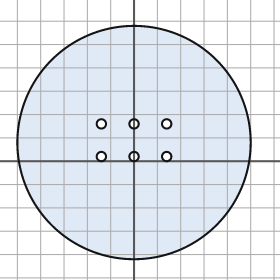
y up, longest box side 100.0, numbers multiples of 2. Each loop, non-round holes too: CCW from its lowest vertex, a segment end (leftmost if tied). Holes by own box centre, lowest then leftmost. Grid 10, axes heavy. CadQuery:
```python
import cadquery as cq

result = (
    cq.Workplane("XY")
    .moveTo(0.0, 8.0)
    .circle(50.0)
    .moveTo(-14.0, 2.0)
    .circle(2.0)
    .moveTo(0.0, 2.0)
    .circle(2.0)
    .moveTo(14.0, 2.0)
    .circle(2.0)
    .moveTo(-14.0, 16.0)
    .circle(2.0)
    .moveTo(0.0, 16.0)
    .circle(2.0)
    .moveTo(14.0, 16.0)
    .circle(2.0)
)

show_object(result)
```